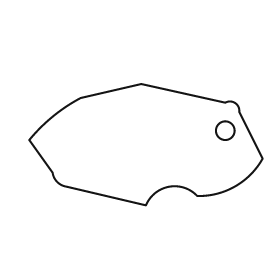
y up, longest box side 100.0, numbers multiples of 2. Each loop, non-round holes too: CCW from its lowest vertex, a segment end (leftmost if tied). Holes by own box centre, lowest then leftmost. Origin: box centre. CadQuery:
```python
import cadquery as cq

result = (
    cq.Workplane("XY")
    .moveTo(0.0, -26.0)
    .threePointArc((10.0, -18.0), (22.0, -22.0))
    .threePointArc((38.0, -18.0), (50.0, -6.0))
    .lineTo(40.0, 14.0)
    .threePointArc((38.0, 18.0), (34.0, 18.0))
    .lineTo(-2.0, 26.0)
    .lineTo(-28.0, 20.0)
    .threePointArc((-40.0, 12.0), (-50.0, 2.0))
    .lineTo(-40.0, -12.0)
    .threePointArc((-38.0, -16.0), (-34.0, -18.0))
    .close()
    .moveTo(34.0, 6.0)
    .circle(4.0)
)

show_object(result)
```